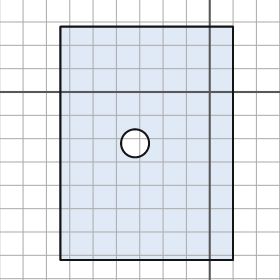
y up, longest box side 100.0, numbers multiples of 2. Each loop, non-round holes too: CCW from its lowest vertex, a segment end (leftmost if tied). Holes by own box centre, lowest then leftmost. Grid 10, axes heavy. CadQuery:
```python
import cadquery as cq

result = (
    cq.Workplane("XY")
    .moveTo(-64.0, -72.0)
    .lineTo(10.0, -72.0)
    .lineTo(10.0, 28.0)
    .lineTo(-64.0, 28.0)
    .close()
    .moveTo(-32.0, -22.0)
    .circle(6.0)
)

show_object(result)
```